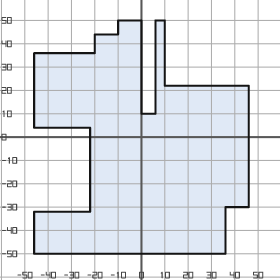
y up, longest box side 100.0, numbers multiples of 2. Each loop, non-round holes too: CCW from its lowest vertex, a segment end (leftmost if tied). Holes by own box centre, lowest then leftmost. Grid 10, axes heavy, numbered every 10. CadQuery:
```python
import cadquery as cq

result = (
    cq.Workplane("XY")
    .moveTo(-46.0, -50.0)
    .lineTo(36.0, -50.0)
    .lineTo(36.0, -30.0)
    .lineTo(46.0, -30.0)
    .lineTo(46.0, 22.0)
    .lineTo(10.0, 22.0)
    .lineTo(10.0, 50.0)
    .lineTo(6.0, 50.0)
    .lineTo(6.0, 10.0)
    .lineTo(0.0, 10.0)
    .lineTo(0.0, 50.0)
    .lineTo(-10.0, 50.0)
    .lineTo(-10.0, 44.0)
    .lineTo(-20.0, 44.0)
    .lineTo(-20.0, 36.0)
    .lineTo(-46.0, 36.0)
    .lineTo(-46.0, 4.0)
    .lineTo(-22.0, 4.0)
    .lineTo(-22.0, -32.0)
    .lineTo(-46.0, -32.0)
    .close()
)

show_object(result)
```